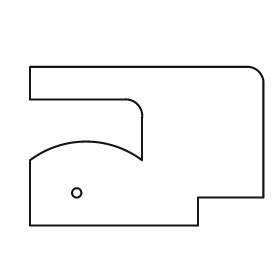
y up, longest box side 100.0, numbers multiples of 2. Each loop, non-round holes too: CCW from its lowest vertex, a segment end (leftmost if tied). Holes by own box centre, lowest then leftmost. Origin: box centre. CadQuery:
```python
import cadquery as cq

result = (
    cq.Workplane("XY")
    .moveTo(-50.0, -34.0)
    .lineTo(22.0, -34.0)
    .lineTo(22.0, -22.0)
    .lineTo(50.0, -22.0)
    .lineTo(50.0, 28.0)
    .threePointArc((48.0, 32.0), (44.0, 34.0))
    .lineTo(-50.0, 34.0)
    .lineTo(-50.0, 20.0)
    .lineTo(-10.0, 20.0)
    .threePointArc((-4.0, 18.0), (-2.0, 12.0))
    .lineTo(-2.0, -6.0)
    .threePointArc((-26.0, 2.0), (-50.0, -6.0))
    .close()
    .moveTo(-30.0, -20.0)
    .circle(2.0)
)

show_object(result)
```